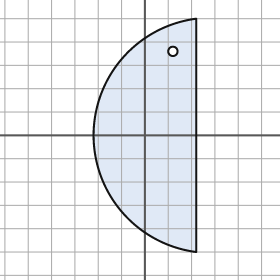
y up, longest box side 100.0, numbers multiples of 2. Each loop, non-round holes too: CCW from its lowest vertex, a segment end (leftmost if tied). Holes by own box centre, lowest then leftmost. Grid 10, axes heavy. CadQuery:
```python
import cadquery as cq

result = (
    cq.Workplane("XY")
    .moveTo(22.0, -50.0)
    .lineTo(22.0, 50.0)
    .threePointArc((-22.0, 0.0), (22.0, -50.0))
    .close()
    .moveTo(12.0, 36.0)
    .circle(2.0)
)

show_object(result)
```